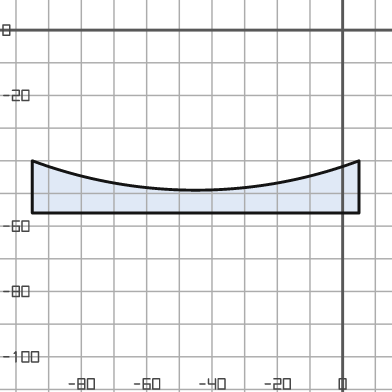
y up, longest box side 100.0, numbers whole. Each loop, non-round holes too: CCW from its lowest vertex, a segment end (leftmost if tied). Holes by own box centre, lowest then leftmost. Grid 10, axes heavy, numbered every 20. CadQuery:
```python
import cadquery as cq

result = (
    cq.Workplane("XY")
    .moveTo(-95.0, -56.0)
    .lineTo(5.0, -56.0)
    .lineTo(5.0, -40.0)
    .threePointArc((-45.0, -49.0), (-95.0, -40.0))
    .close()
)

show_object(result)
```